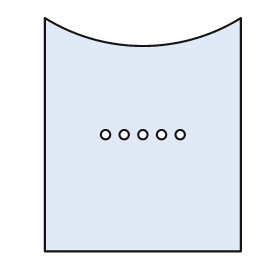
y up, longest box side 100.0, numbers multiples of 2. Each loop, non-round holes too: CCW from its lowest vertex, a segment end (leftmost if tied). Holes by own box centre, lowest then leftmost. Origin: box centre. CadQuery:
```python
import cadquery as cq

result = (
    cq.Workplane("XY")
    .moveTo(-42.0, -50.0)
    .lineTo(42.0, -50.0)
    .lineTo(42.0, 50.0)
    .threePointArc((0.0, 38.0), (-42.0, 50.0))
    .close()
    .moveTo(-16.0, 0.0)
    .circle(2.0)
    .moveTo(-8.0, 0.0)
    .circle(2.0)
    .moveTo(0.0, 0.0)
    .circle(2.0)
    .moveTo(8.0, 0.0)
    .circle(2.0)
    .moveTo(16.0, 0.0)
    .circle(2.0)
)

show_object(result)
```